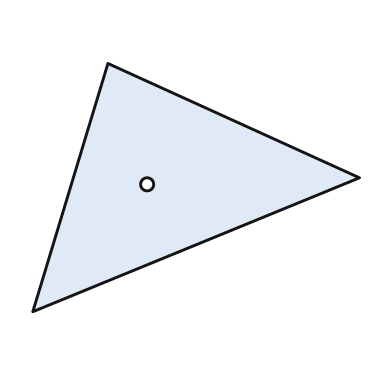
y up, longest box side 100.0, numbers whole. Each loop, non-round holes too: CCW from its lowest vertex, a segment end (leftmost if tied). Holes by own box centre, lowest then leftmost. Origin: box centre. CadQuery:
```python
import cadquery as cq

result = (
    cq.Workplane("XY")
    .moveTo(-50.0, -38.0)
    .lineTo(50.0, 3.0)
    .lineTo(-27.0, 38.0)
    .close()
    .moveTo(-15.0, 1.0)
    .circle(2.0)
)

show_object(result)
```